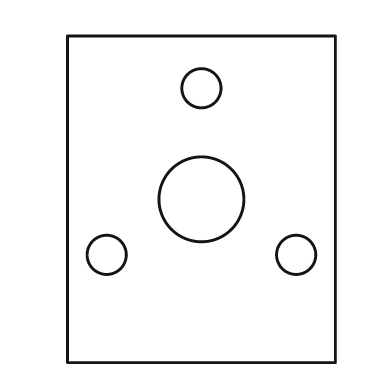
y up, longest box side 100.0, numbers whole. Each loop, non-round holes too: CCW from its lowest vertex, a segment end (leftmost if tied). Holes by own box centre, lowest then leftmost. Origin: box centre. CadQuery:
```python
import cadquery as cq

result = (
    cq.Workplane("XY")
    .moveTo(-41.0, -50.0)
    .lineTo(41.0, -50.0)
    .lineTo(41.0, 50.0)
    .lineTo(-41.0, 50.0)
    .close()
    .moveTo(-29.0, -17.0)
    .circle(6.0)
    .moveTo(29.0, -17.0)
    .circle(6.0)
    .moveTo(0.0, 0.0)
    .circle(13.0)
    .moveTo(0.0, 34.0)
    .circle(6.0)
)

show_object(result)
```